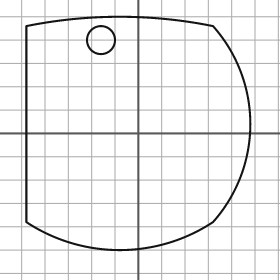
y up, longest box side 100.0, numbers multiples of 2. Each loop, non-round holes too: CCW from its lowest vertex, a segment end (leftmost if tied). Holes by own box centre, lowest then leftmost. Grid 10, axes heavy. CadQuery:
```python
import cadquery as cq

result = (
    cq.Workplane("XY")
    .moveTo(-48.0, -38.0)
    .threePointArc((-8.0, -50.0), (32.0, -38.0))
    .threePointArc((48.0, 4.0), (32.0, 46.0))
    .threePointArc((-8.0, 50.0), (-48.0, 46.0))
    .close()
    .moveTo(-16.0, 40.0)
    .circle(6.0)
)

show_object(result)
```